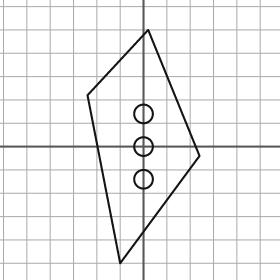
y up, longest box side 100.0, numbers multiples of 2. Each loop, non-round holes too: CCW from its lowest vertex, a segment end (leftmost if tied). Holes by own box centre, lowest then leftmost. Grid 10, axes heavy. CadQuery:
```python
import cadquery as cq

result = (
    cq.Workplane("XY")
    .moveTo(-10.0, -50.0)
    .lineTo(24.0, -4.0)
    .lineTo(2.0, 50.0)
    .lineTo(-24.0, 22.0)
    .close()
    .moveTo(0.0, -14.0)
    .circle(4.0)
    .moveTo(0.0, 0.0)
    .circle(4.0)
    .moveTo(0.0, 14.0)
    .circle(4.0)
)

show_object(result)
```